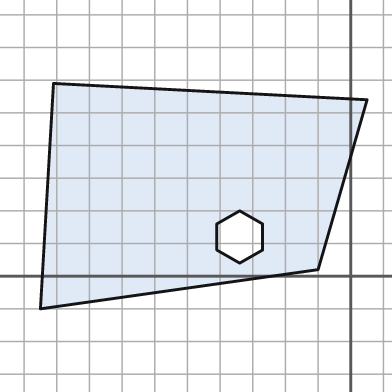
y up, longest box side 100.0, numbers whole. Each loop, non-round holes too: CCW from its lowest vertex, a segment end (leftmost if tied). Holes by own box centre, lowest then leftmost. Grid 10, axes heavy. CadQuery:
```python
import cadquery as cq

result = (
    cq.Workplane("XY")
    .moveTo(-95.0, -10.0)
    .lineTo(-10.0, 2.0)
    .lineTo(5.0, 54.0)
    .lineTo(-91.0, 59.0)
    .close()
    .moveTo(-34.0, 4.0)
    .lineTo(-27.0, 8.0)
    .lineTo(-27.0, 16.0)
    .lineTo(-34.0, 20.0)
    .lineTo(-41.0, 16.0)
    .lineTo(-41.0, 8.0)
    .close()
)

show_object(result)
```